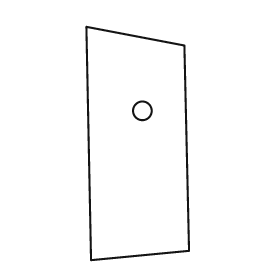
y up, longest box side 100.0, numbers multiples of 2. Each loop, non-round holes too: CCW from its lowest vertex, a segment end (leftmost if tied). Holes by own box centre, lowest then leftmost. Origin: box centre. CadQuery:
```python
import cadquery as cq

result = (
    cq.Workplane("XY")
    .moveTo(-20.0, -50.0)
    .lineTo(22.0, -46.0)
    .lineTo(20.0, 42.0)
    .lineTo(-22.0, 50.0)
    .close()
    .moveTo(2.0, 14.0)
    .circle(4.0)
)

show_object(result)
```